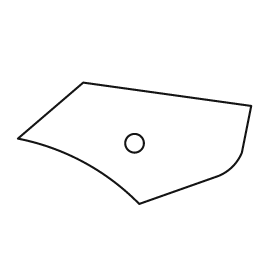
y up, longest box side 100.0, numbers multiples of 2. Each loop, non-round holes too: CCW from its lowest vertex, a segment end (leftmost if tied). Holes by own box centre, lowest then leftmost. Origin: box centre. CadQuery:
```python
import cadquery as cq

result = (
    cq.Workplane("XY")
    .moveTo(2.0, -26.0)
    .lineTo(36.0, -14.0)
    .threePointArc((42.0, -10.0), (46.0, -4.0))
    .lineTo(50.0, 16.0)
    .lineTo(-22.0, 26.0)
    .lineTo(-50.0, 2.0)
    .threePointArc((-22.0, -8.0), (2.0, -26.0))
    .close()
    .moveTo(0.0, 0.0)
    .circle(4.0)
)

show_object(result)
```